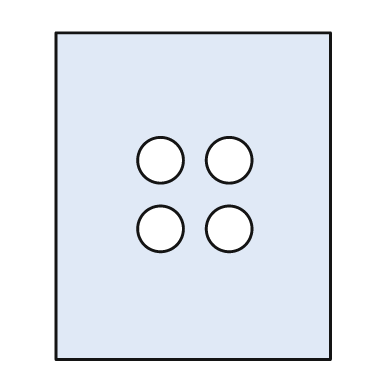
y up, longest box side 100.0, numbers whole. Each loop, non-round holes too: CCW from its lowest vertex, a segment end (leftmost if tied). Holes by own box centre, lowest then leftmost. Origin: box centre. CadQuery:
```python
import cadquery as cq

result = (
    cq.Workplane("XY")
    .moveTo(-42.0, -50.0)
    .lineTo(42.0, -50.0)
    .lineTo(42.0, 50.0)
    .lineTo(-42.0, 50.0)
    .close()
    .moveTo(-10.0, -10.0)
    .circle(7.0)
    .moveTo(11.0, -10.0)
    .circle(7.0)
    .moveTo(-10.0, 11.0)
    .circle(7.0)
    .moveTo(11.0, 11.0)
    .circle(7.0)
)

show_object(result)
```